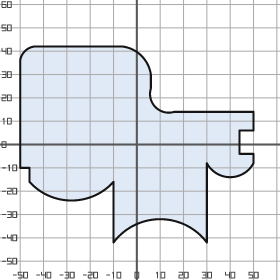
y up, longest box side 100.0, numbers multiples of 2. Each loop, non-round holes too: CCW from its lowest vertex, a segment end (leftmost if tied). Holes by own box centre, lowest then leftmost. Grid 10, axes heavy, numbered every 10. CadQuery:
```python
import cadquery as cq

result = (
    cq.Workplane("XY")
    .moveTo(-10.0, -42.0)
    .threePointArc((10.0, -32.0), (30.0, -42.0))
    .lineTo(30.0, -8.0)
    .threePointArc((40.0, -14.0), (50.0, -8.0))
    .lineTo(50.0, -4.0)
    .lineTo(44.0, -4.0)
    .lineTo(44.0, 6.0)
    .lineTo(50.0, 6.0)
    .lineTo(50.0, 14.0)
    .lineTo(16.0, 14.0)
    .threePointArc((8.0, 16.0), (6.0, 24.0))
    .lineTo(6.0, 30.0)
    .threePointArc((2.0, 38.0), (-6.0, 42.0))
    .lineTo(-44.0, 42.0)
    .threePointArc((-48.0, 40.0), (-50.0, 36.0))
    .lineTo(-50.0, -10.0)
    .lineTo(-46.0, -10.0)
    .lineTo(-46.0, -16.0)
    .threePointArc((-28.0, -24.0), (-10.0, -16.0))
    .close()
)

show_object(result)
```